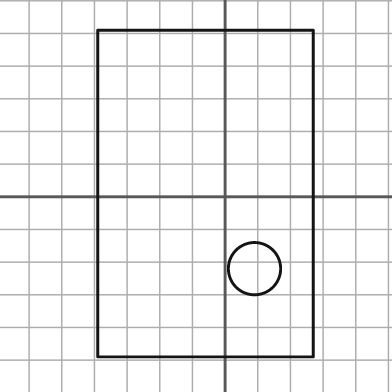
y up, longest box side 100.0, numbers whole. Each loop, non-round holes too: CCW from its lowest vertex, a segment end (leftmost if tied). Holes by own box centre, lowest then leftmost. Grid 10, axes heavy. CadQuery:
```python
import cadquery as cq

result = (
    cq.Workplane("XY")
    .moveTo(-39.0, -49.0)
    .lineTo(27.0, -49.0)
    .lineTo(27.0, 51.0)
    .lineTo(-39.0, 51.0)
    .close()
    .moveTo(9.0, -22.0)
    .circle(8.0)
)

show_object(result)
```